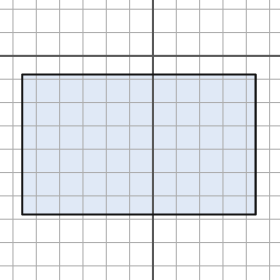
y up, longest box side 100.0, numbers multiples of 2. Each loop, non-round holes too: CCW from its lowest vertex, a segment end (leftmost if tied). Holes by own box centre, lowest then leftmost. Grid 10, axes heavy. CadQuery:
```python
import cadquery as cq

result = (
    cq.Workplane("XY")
    .moveTo(-56.0, -68.0)
    .lineTo(44.0, -68.0)
    .lineTo(44.0, -8.0)
    .lineTo(-56.0, -8.0)
    .close()
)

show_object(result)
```